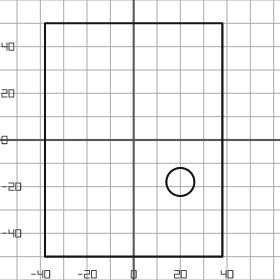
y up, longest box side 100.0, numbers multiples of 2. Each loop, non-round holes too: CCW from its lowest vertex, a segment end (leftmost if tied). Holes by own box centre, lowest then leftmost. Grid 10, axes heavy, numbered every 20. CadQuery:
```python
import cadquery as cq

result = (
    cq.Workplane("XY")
    .moveTo(-38.0, -50.0)
    .lineTo(38.0, -50.0)
    .lineTo(38.0, 50.0)
    .lineTo(-38.0, 50.0)
    .close()
    .moveTo(20.0, -18.0)
    .circle(6.0)
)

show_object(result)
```